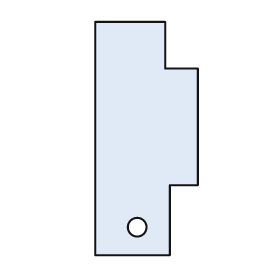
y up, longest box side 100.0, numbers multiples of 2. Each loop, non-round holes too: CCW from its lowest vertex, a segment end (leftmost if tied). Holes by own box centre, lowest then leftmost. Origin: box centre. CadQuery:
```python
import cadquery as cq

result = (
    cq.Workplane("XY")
    .moveTo(-22.0, -50.0)
    .lineTo(10.0, -50.0)
    .lineTo(10.0, -20.0)
    .lineTo(22.0, -20.0)
    .lineTo(22.0, 30.0)
    .lineTo(8.0, 30.0)
    .lineTo(8.0, 50.0)
    .lineTo(-22.0, 50.0)
    .close()
    .moveTo(-4.0, -38.0)
    .circle(4.0)
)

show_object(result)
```